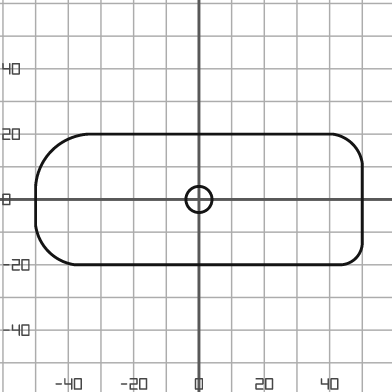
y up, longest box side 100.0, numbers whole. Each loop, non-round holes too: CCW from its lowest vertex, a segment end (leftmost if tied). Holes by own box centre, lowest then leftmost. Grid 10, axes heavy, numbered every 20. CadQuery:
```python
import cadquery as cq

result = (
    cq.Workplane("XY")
    .moveTo(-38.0, -20.0)
    .lineTo(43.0, -20.0)
    .threePointArc((48.0, -18.0), (50.0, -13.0))
    .lineTo(50.0, 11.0)
    .threePointArc((47.0, 17.0), (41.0, 20.0))
    .lineTo(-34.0, 20.0)
    .threePointArc((-45.0, 15.0), (-50.0, 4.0))
    .lineTo(-50.0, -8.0)
    .threePointArc((-46.0, -16.0), (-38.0, -20.0))
    .close()
    .moveTo(0.0, 0.0)
    .circle(4.0)
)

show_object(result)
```